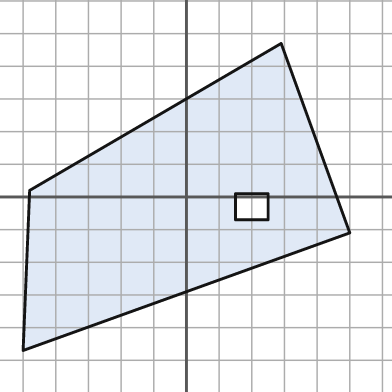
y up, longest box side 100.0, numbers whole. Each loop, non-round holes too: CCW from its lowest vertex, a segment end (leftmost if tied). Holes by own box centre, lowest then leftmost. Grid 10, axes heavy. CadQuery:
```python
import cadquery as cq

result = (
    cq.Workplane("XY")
    .moveTo(-50.0, -47.0)
    .lineTo(50.0, -11.0)
    .lineTo(29.0, 47.0)
    .lineTo(-48.0, 2.0)
    .close()
    .moveTo(15.0, -7.0)
    .lineTo(25.0, -7.0)
    .lineTo(25.0, 1.0)
    .lineTo(15.0, 1.0)
    .close()
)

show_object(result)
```